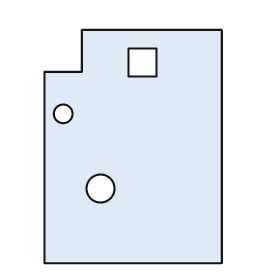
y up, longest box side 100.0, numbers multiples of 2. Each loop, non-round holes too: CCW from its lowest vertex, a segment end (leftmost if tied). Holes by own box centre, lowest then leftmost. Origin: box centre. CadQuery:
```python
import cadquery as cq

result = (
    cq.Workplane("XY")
    .moveTo(-38.0, -50.0)
    .lineTo(38.0, -50.0)
    .lineTo(38.0, 50.0)
    .lineTo(-22.0, 50.0)
    .lineTo(-22.0, 32.0)
    .lineTo(-38.0, 32.0)
    .close()
    .moveTo(-14.0, -18.0)
    .circle(6.0)
    .moveTo(-30.0, 14.0)
    .circle(4.0)
    .moveTo(-2.0, 30.0)
    .lineTo(10.0, 30.0)
    .lineTo(10.0, 42.0)
    .lineTo(-2.0, 42.0)
    .close()
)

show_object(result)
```